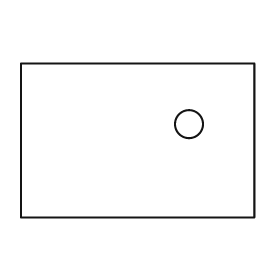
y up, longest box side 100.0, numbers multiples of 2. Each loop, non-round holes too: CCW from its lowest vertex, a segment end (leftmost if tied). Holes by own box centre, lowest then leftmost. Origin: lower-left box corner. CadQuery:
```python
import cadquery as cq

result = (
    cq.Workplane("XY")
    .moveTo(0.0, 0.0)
    .lineTo(100.0, 0.0)
    .lineTo(100.0, 66.0)
    .lineTo(0.0, 66.0)
    .close()
    .moveTo(72.0, 40.0)
    .circle(6.0)
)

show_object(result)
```